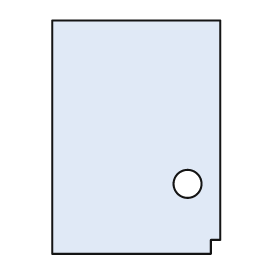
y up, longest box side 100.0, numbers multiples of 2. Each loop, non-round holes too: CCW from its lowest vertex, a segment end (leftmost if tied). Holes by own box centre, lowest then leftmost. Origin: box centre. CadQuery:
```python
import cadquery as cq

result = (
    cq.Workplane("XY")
    .moveTo(-36.0, -50.0)
    .lineTo(32.0, -50.0)
    .lineTo(32.0, -44.0)
    .lineTo(36.0, -44.0)
    .lineTo(36.0, 50.0)
    .lineTo(-36.0, 50.0)
    .close()
    .moveTo(22.0, -20.0)
    .circle(6.0)
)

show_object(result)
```